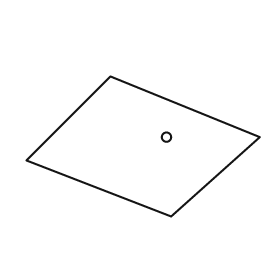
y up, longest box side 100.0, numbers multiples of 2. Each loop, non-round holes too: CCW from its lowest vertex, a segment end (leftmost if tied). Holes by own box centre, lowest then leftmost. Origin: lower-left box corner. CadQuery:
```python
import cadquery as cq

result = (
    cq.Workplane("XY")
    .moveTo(62.0, 0.0)
    .lineTo(100.0, 34.0)
    .lineTo(36.0, 60.0)
    .lineTo(0.0, 24.0)
    .close()
    .moveTo(60.0, 34.0)
    .circle(2.0)
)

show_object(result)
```